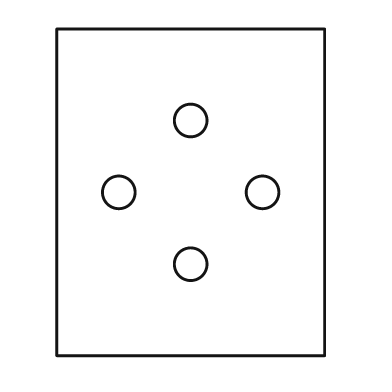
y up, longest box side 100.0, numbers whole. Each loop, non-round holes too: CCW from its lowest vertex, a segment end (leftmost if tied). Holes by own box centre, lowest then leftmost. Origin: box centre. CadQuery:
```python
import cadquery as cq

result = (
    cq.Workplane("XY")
    .moveTo(-41.0, -50.0)
    .lineTo(41.0, -50.0)
    .lineTo(41.0, 50.0)
    .lineTo(-41.0, 50.0)
    .close()
    .moveTo(0.0, -22.0)
    .circle(5.0)
    .moveTo(-22.0, 0.0)
    .circle(5.0)
    .moveTo(22.0, 0.0)
    .circle(5.0)
    .moveTo(0.0, 22.0)
    .circle(5.0)
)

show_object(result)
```